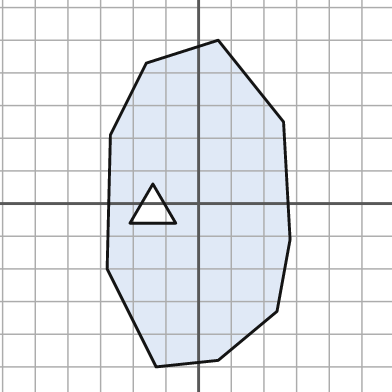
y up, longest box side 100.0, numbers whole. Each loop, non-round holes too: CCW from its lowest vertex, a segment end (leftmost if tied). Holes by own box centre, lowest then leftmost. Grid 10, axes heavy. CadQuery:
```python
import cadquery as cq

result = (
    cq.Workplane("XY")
    .moveTo(-13.0, -50.0)
    .lineTo(6.0, -48.0)
    .lineTo(24.0, -33.0)
    .lineTo(28.0, -11.0)
    .lineTo(26.0, 25.0)
    .lineTo(6.0, 50.0)
    .lineTo(-16.0, 43.0)
    .lineTo(-27.0, 21.0)
    .lineTo(-28.0, -20.0)
    .close()
    .moveTo(-21.0, -6.0)
    .lineTo(-7.0, -6.0)
    .lineTo(-14.0, 6.0)
    .close()
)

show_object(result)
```